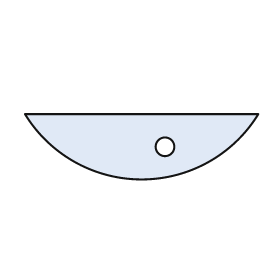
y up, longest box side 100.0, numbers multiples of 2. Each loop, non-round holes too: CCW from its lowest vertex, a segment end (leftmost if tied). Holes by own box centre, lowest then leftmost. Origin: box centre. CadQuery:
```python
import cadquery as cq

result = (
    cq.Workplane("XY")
    .moveTo(-50.0, 14.0)
    .threePointArc((0.0, -14.0), (50.0, 14.0))
    .close()
    .moveTo(10.0, 0.0)
    .circle(4.0)
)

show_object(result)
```